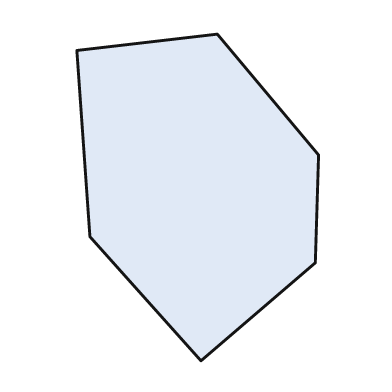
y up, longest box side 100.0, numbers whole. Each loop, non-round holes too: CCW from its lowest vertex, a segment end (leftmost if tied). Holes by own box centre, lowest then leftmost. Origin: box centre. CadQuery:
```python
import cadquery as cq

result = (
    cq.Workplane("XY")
    .moveTo(1.0, -50.0)
    .lineTo(36.0, -20.0)
    .lineTo(37.0, 13.0)
    .lineTo(6.0, 50.0)
    .lineTo(-37.0, 45.0)
    .lineTo(-33.0, -12.0)
    .close()
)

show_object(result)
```